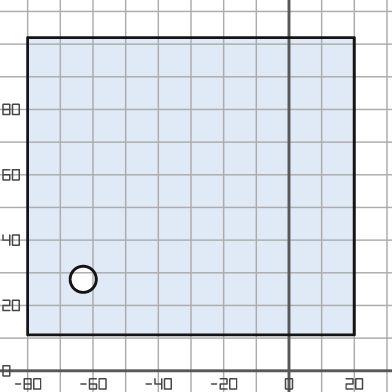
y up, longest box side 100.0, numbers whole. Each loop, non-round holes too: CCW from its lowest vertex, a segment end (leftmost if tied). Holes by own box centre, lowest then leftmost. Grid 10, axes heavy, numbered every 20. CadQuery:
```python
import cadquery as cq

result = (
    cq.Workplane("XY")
    .moveTo(-80.0, 11.0)
    .lineTo(20.0, 11.0)
    .lineTo(20.0, 102.0)
    .lineTo(-80.0, 102.0)
    .close()
    .moveTo(-63.0, 28.0)
    .circle(4.0)
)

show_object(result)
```